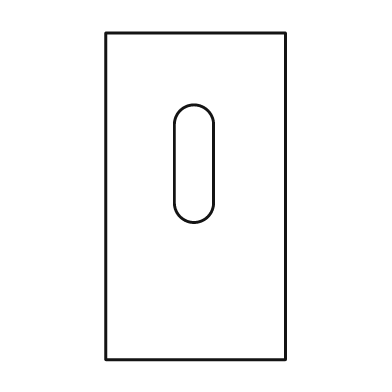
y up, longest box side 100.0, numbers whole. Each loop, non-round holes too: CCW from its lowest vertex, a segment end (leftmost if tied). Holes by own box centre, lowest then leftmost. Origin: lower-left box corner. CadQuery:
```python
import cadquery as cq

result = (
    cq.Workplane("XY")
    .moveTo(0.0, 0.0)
    .lineTo(55.0, 0.0)
    .lineTo(55.0, 100.0)
    .lineTo(0.0, 100.0)
    .close()
    .moveTo(21.0, 48.0)
    .threePointArc((27.0, 42.0), (33.0, 48.0))
    .lineTo(33.0, 72.0)
    .threePointArc((27.0, 78.0), (21.0, 72.0))
    .close()
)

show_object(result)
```